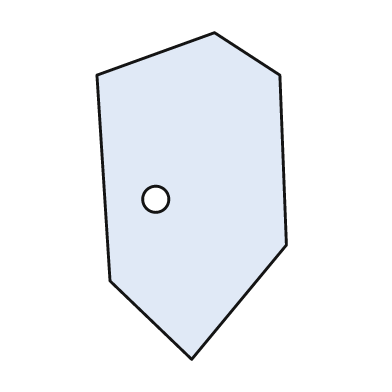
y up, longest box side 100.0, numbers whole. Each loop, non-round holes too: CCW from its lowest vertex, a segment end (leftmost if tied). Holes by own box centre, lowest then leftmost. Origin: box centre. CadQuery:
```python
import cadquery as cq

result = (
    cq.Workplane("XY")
    .moveTo(0.0, -50.0)
    .lineTo(29.0, -15.0)
    .lineTo(27.0, 37.0)
    .lineTo(7.0, 50.0)
    .lineTo(-29.0, 37.0)
    .lineTo(-25.0, -26.0)
    .close()
    .moveTo(-11.0, -1.0)
    .circle(4.0)
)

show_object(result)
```